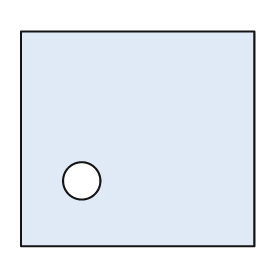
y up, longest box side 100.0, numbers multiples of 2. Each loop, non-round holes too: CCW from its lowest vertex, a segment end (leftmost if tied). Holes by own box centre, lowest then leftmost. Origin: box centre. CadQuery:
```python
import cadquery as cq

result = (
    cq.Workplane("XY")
    .moveTo(-50.0, -46.0)
    .lineTo(50.0, -46.0)
    .lineTo(50.0, 46.0)
    .lineTo(-50.0, 46.0)
    .close()
    .moveTo(-24.0, -18.0)
    .circle(8.0)
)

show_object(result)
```